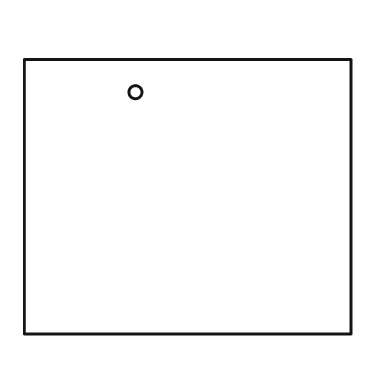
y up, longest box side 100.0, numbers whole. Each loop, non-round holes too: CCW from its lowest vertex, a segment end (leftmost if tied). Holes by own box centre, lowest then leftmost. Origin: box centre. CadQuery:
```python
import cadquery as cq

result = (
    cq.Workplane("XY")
    .moveTo(-50.0, -42.0)
    .lineTo(50.0, -42.0)
    .lineTo(50.0, 42.0)
    .lineTo(-50.0, 42.0)
    .close()
    .moveTo(-16.0, 32.0)
    .circle(2.0)
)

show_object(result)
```